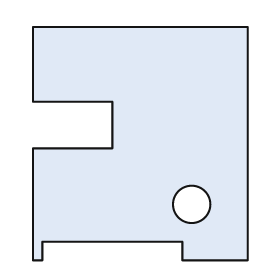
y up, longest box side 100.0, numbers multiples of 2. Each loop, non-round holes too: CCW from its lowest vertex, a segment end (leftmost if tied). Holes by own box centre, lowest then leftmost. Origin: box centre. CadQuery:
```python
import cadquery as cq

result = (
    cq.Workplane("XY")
    .moveTo(-46.0, -50.0)
    .lineTo(-42.0, -50.0)
    .lineTo(-42.0, -42.0)
    .lineTo(18.0, -42.0)
    .lineTo(18.0, -50.0)
    .lineTo(46.0, -50.0)
    .lineTo(46.0, 50.0)
    .lineTo(-46.0, 50.0)
    .lineTo(-46.0, 18.0)
    .lineTo(-12.0, 18.0)
    .lineTo(-12.0, -2.0)
    .lineTo(-46.0, -2.0)
    .close()
    .moveTo(22.0, -26.0)
    .circle(8.0)
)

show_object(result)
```